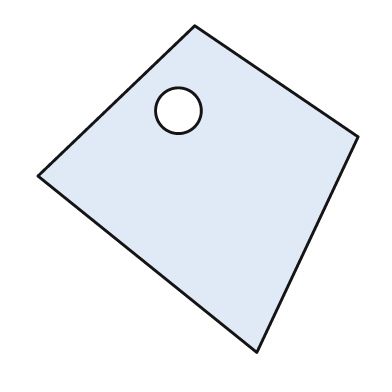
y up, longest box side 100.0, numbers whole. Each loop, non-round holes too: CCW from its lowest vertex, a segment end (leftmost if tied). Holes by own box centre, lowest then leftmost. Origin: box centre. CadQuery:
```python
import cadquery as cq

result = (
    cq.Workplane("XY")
    .moveTo(18.0, -50.0)
    .lineTo(49.0, 16.0)
    .lineTo(-1.0, 50.0)
    .lineTo(-49.0, 4.0)
    .close()
    .moveTo(-6.0, 24.0)
    .circle(7.0)
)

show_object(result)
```